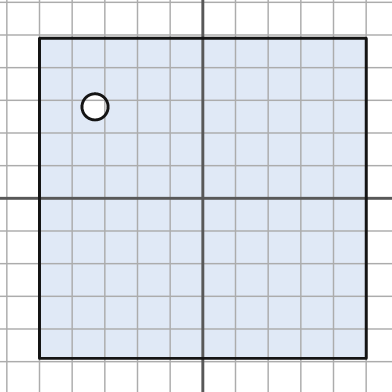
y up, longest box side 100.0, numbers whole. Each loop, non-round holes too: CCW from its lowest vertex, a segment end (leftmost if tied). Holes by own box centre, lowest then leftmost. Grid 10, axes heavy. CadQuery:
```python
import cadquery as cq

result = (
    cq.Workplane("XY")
    .moveTo(-50.0, -49.0)
    .lineTo(50.0, -49.0)
    .lineTo(50.0, 49.0)
    .lineTo(-50.0, 49.0)
    .close()
    .moveTo(-33.0, 28.0)
    .circle(4.0)
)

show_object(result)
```